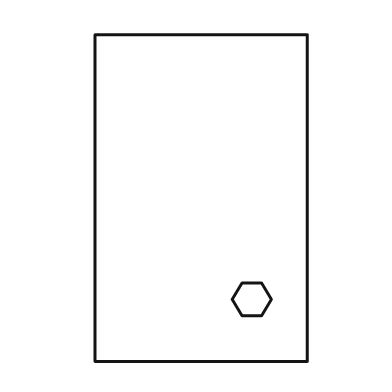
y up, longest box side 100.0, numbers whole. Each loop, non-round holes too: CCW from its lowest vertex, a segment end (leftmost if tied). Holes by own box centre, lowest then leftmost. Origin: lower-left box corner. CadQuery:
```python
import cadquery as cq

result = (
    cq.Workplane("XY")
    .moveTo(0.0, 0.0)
    .lineTo(65.0, 0.0)
    .lineTo(65.0, 100.0)
    .lineTo(0.0, 100.0)
    .close()
    .moveTo(45.0, 14.0)
    .lineTo(51.0, 14.0)
    .lineTo(54.0, 19.0)
    .lineTo(51.0, 24.0)
    .lineTo(45.0, 24.0)
    .lineTo(42.0, 19.0)
    .close()
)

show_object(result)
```